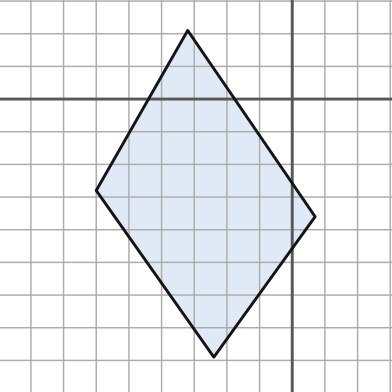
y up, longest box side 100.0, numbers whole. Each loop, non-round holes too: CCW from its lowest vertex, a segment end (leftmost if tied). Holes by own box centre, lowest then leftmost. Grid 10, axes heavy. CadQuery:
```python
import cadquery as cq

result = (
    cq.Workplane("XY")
    .moveTo(-24.0, -79.0)
    .lineTo(7.0, -36.0)
    .lineTo(-32.0, 21.0)
    .lineTo(-60.0, -28.0)
    .close()
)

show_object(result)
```